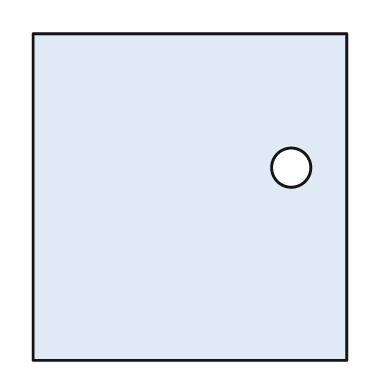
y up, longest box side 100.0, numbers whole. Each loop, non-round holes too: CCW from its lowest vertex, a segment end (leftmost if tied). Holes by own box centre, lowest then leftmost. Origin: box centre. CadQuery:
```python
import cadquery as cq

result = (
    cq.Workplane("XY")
    .moveTo(-48.0, -50.0)
    .lineTo(48.0, -50.0)
    .lineTo(48.0, 50.0)
    .lineTo(-48.0, 50.0)
    .close()
    .moveTo(31.0, 9.0)
    .circle(6.0)
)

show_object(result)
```